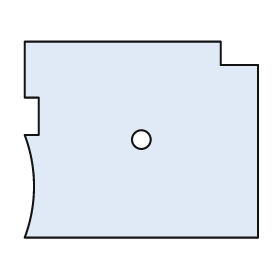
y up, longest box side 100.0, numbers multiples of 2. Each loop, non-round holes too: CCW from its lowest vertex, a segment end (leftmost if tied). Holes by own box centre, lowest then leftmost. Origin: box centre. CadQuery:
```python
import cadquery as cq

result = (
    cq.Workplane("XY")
    .moveTo(-50.0, -42.0)
    .lineTo(50.0, -42.0)
    .lineTo(50.0, 32.0)
    .lineTo(34.0, 32.0)
    .lineTo(34.0, 42.0)
    .lineTo(-50.0, 42.0)
    .lineTo(-50.0, 18.0)
    .lineTo(-44.0, 18.0)
    .lineTo(-44.0, 2.0)
    .lineTo(-50.0, 2.0)
    .threePointArc((-46.0, -20.0), (-50.0, -42.0))
    .close()
    .moveTo(0.0, 0.0)
    .circle(4.0)
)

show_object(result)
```